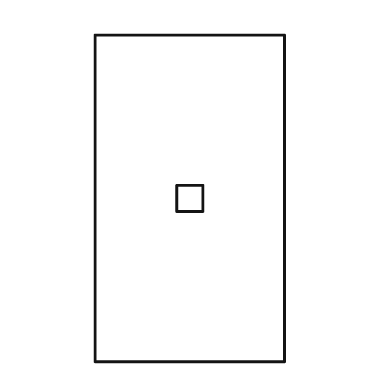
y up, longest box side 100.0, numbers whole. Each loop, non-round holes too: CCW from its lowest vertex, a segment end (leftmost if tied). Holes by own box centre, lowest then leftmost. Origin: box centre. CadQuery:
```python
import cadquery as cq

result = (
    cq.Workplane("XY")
    .moveTo(-29.0, -50.0)
    .lineTo(29.0, -50.0)
    .lineTo(29.0, 50.0)
    .lineTo(-29.0, 50.0)
    .close()
    .moveTo(-4.0, -4.0)
    .lineTo(4.0, -4.0)
    .lineTo(4.0, 4.0)
    .lineTo(-4.0, 4.0)
    .close()
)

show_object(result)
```